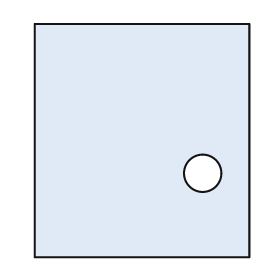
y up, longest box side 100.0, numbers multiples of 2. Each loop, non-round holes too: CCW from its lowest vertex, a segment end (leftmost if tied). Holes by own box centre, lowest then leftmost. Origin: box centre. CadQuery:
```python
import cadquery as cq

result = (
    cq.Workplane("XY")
    .moveTo(-46.0, -50.0)
    .lineTo(46.0, -50.0)
    .lineTo(46.0, 50.0)
    .lineTo(-46.0, 50.0)
    .close()
    .moveTo(26.0, -14.0)
    .circle(8.0)
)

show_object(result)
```